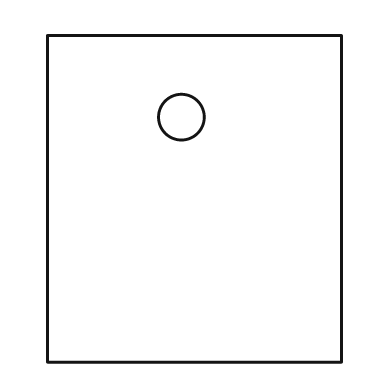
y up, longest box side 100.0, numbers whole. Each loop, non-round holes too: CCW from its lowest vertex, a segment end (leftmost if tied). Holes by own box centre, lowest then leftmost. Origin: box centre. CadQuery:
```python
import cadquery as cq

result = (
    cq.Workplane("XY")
    .moveTo(-45.0, -50.0)
    .lineTo(45.0, -50.0)
    .lineTo(45.0, 50.0)
    .lineTo(-45.0, 50.0)
    .close()
    .moveTo(-4.0, 25.0)
    .circle(7.0)
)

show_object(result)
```